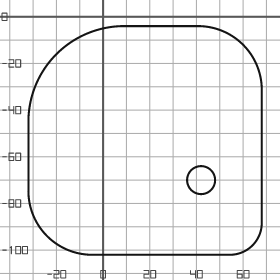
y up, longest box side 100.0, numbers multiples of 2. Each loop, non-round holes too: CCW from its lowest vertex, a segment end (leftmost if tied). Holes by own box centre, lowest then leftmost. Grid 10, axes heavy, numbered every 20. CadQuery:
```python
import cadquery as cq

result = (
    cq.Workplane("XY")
    .moveTo(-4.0, -102.0)
    .lineTo(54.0, -102.0)
    .threePointArc((64.0, -98.0), (68.0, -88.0))
    .lineTo(68.0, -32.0)
    .threePointArc((60.0, -12.0), (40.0, -4.0))
    .lineTo(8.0, -4.0)
    .threePointArc((-20.0, -16.0), (-32.0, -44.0))
    .lineTo(-32.0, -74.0)
    .threePointArc((-24.0, -94.0), (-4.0, -102.0))
    .close()
    .moveTo(42.0, -70.0)
    .circle(6.0)
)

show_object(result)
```